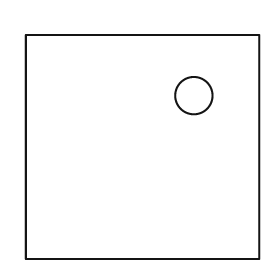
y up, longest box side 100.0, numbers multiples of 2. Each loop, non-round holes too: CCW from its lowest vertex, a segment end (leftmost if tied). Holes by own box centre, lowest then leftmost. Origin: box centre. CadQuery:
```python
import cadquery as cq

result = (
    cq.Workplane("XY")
    .moveTo(-50.0, -48.0)
    .lineTo(50.0, -48.0)
    .lineTo(50.0, 48.0)
    .lineTo(-50.0, 48.0)
    .close()
    .moveTo(22.0, 22.0)
    .circle(8.0)
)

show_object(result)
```